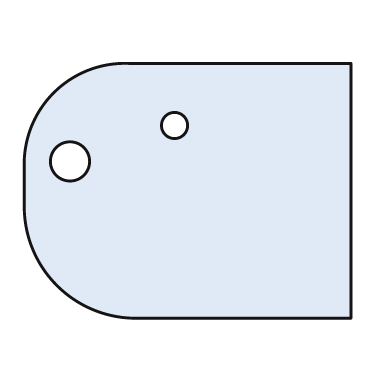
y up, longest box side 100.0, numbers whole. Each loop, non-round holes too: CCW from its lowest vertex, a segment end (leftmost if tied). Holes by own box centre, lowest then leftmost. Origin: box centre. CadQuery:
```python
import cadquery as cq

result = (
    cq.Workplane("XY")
    .moveTo(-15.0, -39.0)
    .lineTo(50.0, -39.0)
    .lineTo(50.0, 39.0)
    .lineTo(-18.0, 39.0)
    .threePointArc((-41.0, 30.0), (-50.0, 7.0))
    .lineTo(-50.0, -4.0)
    .threePointArc((-40.0, -29.0), (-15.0, -39.0))
    .close()
    .moveTo(-36.0, 9.0)
    .circle(6.0)
    .moveTo(-4.0, 20.0)
    .circle(4.0)
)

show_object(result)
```